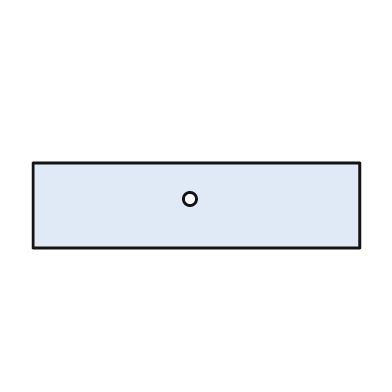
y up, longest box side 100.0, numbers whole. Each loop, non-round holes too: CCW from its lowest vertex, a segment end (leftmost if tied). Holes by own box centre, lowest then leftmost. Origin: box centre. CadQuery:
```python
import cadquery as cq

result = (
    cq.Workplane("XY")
    .moveTo(-50.0, -13.0)
    .lineTo(50.0, -13.0)
    .lineTo(50.0, 13.0)
    .lineTo(-50.0, 13.0)
    .close()
    .moveTo(-2.0, 2.0)
    .circle(2.0)
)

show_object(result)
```